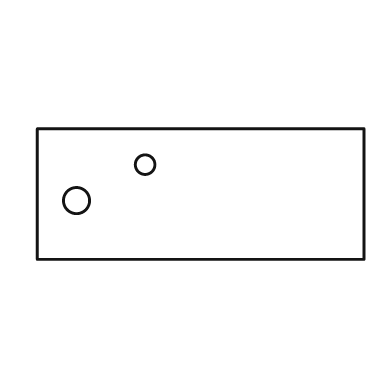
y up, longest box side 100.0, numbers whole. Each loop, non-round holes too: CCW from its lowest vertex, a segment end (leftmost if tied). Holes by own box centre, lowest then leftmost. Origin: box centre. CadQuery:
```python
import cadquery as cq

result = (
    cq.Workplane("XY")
    .moveTo(-50.0, -20.0)
    .lineTo(50.0, -20.0)
    .lineTo(50.0, 20.0)
    .lineTo(-50.0, 20.0)
    .close()
    .moveTo(-38.0, -2.0)
    .circle(4.0)
    .moveTo(-17.0, 9.0)
    .circle(3.0)
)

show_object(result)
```